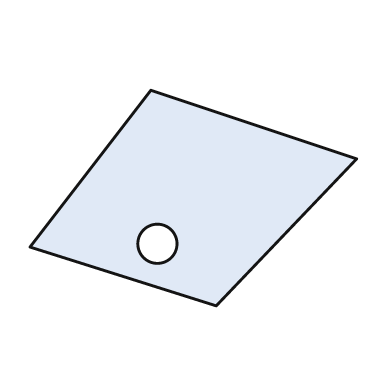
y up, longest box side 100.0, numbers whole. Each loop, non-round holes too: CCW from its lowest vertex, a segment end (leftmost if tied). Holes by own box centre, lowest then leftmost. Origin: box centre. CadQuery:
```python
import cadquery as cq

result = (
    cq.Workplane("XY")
    .moveTo(7.0, -33.0)
    .lineTo(50.0, 12.0)
    .lineTo(-13.0, 33.0)
    .lineTo(-50.0, -15.0)
    .close()
    .moveTo(-11.0, -14.0)
    .circle(6.0)
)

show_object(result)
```